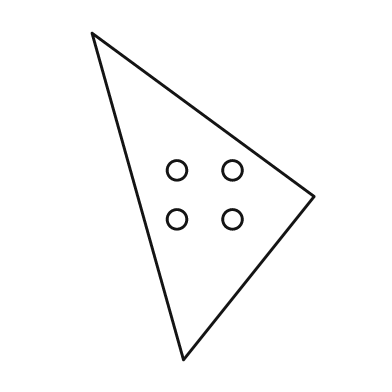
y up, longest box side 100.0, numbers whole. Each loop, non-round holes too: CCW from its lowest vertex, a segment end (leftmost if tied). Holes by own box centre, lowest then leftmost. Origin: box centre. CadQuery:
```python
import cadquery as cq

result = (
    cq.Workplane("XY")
    .moveTo(-6.0, -50.0)
    .lineTo(34.0, 0.0)
    .lineTo(-34.0, 50.0)
    .close()
    .moveTo(-8.0, -7.0)
    .circle(3.0)
    .moveTo(9.0, -7.0)
    .circle(3.0)
    .moveTo(-8.0, 8.0)
    .circle(3.0)
    .moveTo(9.0, 8.0)
    .circle(3.0)
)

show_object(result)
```